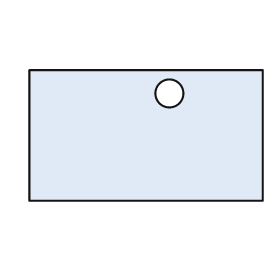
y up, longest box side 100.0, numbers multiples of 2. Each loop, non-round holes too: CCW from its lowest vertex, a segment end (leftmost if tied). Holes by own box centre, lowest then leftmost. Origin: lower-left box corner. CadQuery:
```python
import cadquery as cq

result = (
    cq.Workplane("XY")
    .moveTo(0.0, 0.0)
    .lineTo(100.0, 0.0)
    .lineTo(100.0, 56.0)
    .lineTo(0.0, 56.0)
    .close()
    .moveTo(60.0, 46.0)
    .circle(6.0)
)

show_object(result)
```